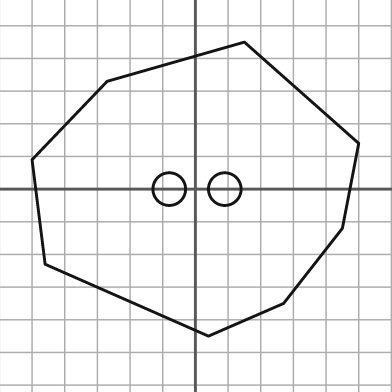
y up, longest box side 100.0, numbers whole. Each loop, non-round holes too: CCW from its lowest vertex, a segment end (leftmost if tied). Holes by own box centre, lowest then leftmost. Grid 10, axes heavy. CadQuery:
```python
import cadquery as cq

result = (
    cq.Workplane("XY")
    .moveTo(4.0, -45.0)
    .lineTo(27.0, -35.0)
    .lineTo(45.0, -12.0)
    .lineTo(50.0, 14.0)
    .lineTo(15.0, 45.0)
    .lineTo(-27.0, 33.0)
    .lineTo(-50.0, 9.0)
    .lineTo(-46.0, -23.0)
    .close()
    .moveTo(-8.0, 0.0)
    .circle(5.0)
    .moveTo(9.0, 0.0)
    .circle(5.0)
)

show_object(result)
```